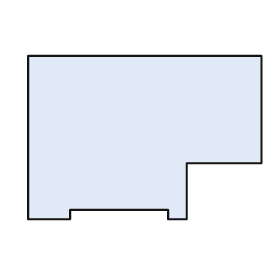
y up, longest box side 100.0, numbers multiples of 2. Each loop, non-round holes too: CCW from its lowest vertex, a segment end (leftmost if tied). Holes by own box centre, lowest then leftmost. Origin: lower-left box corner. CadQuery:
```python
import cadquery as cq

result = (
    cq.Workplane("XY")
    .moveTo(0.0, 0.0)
    .lineTo(18.0, 0.0)
    .lineTo(18.0, 4.0)
    .lineTo(60.0, 4.0)
    .lineTo(60.0, 0.0)
    .lineTo(68.0, 0.0)
    .lineTo(68.0, 24.0)
    .lineTo(100.0, 24.0)
    .lineTo(100.0, 70.0)
    .lineTo(0.0, 70.0)
    .close()
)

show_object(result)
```